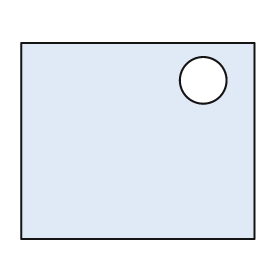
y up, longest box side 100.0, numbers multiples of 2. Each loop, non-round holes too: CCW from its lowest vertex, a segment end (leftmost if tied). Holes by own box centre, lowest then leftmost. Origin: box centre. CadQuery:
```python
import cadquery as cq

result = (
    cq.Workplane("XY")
    .moveTo(-50.0, -42.0)
    .lineTo(50.0, -42.0)
    .lineTo(50.0, 42.0)
    .lineTo(-50.0, 42.0)
    .close()
    .moveTo(28.0, 26.0)
    .circle(10.0)
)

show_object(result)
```